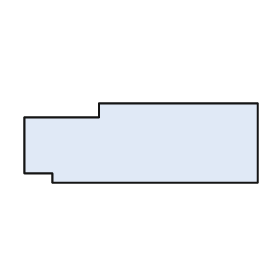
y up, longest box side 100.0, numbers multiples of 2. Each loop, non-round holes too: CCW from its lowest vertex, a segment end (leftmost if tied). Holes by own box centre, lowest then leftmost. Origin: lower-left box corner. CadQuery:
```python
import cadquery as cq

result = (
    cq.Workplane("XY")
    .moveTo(12.0, 0.0)
    .lineTo(100.0, 0.0)
    .lineTo(100.0, 34.0)
    .lineTo(32.0, 34.0)
    .lineTo(32.0, 28.0)
    .lineTo(0.0, 28.0)
    .lineTo(0.0, 4.0)
    .lineTo(12.0, 4.0)
    .close()
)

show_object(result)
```